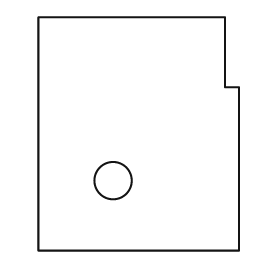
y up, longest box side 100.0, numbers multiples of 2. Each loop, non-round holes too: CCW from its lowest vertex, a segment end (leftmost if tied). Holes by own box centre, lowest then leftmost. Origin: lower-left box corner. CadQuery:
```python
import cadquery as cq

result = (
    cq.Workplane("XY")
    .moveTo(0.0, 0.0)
    .lineTo(86.0, 0.0)
    .lineTo(86.0, 70.0)
    .lineTo(80.0, 70.0)
    .lineTo(80.0, 100.0)
    .lineTo(0.0, 100.0)
    .close()
    .moveTo(32.0, 30.0)
    .circle(8.0)
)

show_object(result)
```